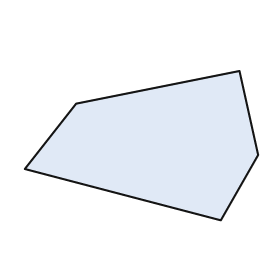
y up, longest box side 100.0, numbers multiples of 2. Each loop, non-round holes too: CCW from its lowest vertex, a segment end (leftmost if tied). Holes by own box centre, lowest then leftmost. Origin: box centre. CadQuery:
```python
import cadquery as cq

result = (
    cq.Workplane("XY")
    .moveTo(34.0, -32.0)
    .lineTo(50.0, -4.0)
    .lineTo(42.0, 32.0)
    .lineTo(-28.0, 18.0)
    .lineTo(-50.0, -10.0)
    .close()
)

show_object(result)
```